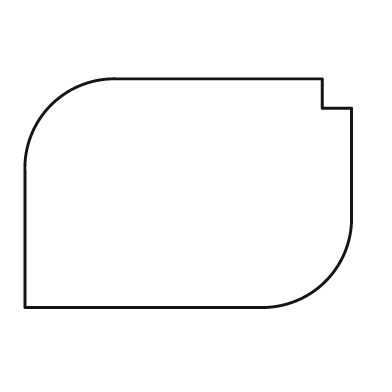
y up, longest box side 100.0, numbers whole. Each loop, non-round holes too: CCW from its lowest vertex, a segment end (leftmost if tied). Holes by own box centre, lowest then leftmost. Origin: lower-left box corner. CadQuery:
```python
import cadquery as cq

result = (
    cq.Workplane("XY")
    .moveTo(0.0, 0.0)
    .lineTo(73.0, 0.0)
    .threePointArc((92.0, 8.0), (100.0, 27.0))
    .lineTo(100.0, 61.0)
    .lineTo(91.0, 61.0)
    .lineTo(91.0, 70.0)
    .lineTo(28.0, 70.0)
    .threePointArc((8.0, 62.0), (0.0, 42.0))
    .close()
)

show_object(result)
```